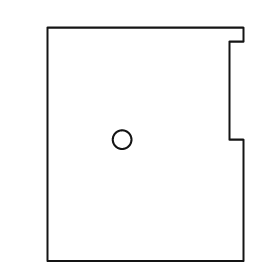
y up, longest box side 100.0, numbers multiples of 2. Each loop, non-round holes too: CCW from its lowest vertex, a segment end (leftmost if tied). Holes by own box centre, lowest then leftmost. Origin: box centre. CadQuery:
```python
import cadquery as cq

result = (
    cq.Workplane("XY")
    .moveTo(-42.0, -50.0)
    .lineTo(42.0, -50.0)
    .lineTo(42.0, 2.0)
    .lineTo(36.0, 2.0)
    .lineTo(36.0, 44.0)
    .lineTo(42.0, 44.0)
    .lineTo(42.0, 50.0)
    .lineTo(-42.0, 50.0)
    .close()
    .moveTo(-10.0, 2.0)
    .circle(4.0)
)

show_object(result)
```